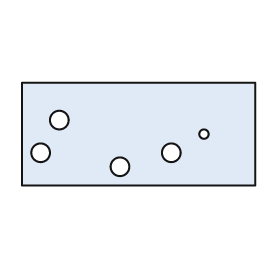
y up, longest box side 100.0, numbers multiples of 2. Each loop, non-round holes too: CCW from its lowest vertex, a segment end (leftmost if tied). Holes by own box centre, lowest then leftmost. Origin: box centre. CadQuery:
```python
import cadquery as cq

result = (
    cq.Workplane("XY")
    .moveTo(-50.0, -22.0)
    .lineTo(50.0, -22.0)
    .lineTo(50.0, 22.0)
    .lineTo(-50.0, 22.0)
    .close()
    .moveTo(-8.0, -14.0)
    .circle(4.0)
    .moveTo(-42.0, -8.0)
    .circle(4.0)
    .moveTo(14.0, -8.0)
    .circle(4.0)
    .moveTo(28.0, 0.0)
    .circle(2.0)
    .moveTo(-34.0, 6.0)
    .circle(4.0)
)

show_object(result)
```